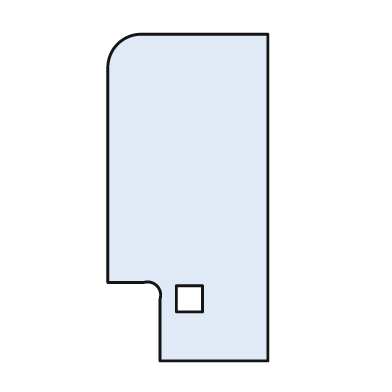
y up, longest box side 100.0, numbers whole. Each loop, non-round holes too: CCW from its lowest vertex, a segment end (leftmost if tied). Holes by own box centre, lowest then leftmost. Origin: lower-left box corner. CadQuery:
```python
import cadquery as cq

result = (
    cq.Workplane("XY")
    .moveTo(16.0, 0.0)
    .lineTo(49.0, 0.0)
    .lineTo(49.0, 100.0)
    .lineTo(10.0, 100.0)
    .threePointArc((3.0, 97.0), (0.0, 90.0))
    .lineTo(0.0, 24.0)
    .lineTo(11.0, 24.0)
    .threePointArc((15.0, 23.0), (16.0, 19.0))
    .close()
    .moveTo(21.0, 15.0)
    .lineTo(29.0, 15.0)
    .lineTo(29.0, 23.0)
    .lineTo(21.0, 23.0)
    .close()
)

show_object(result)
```